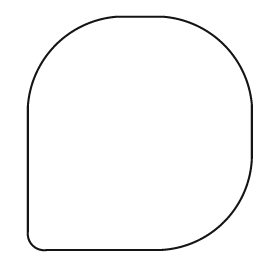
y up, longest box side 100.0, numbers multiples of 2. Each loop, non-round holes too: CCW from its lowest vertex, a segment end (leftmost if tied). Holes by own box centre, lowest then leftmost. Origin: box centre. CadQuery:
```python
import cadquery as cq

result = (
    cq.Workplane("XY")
    .moveTo(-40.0, -50.0)
    .lineTo(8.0, -50.0)
    .threePointArc((36.0, -38.0), (48.0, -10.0))
    .lineTo(48.0, 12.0)
    .threePointArc((36.0, 38.0), (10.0, 50.0))
    .lineTo(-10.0, 50.0)
    .threePointArc((-36.0, 38.0), (-48.0, 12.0))
    .lineTo(-48.0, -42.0)
    .threePointArc((-46.0, -48.0), (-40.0, -50.0))
    .close()
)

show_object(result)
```